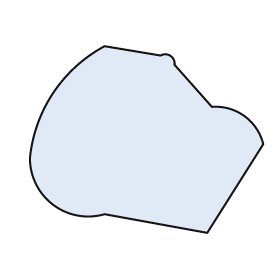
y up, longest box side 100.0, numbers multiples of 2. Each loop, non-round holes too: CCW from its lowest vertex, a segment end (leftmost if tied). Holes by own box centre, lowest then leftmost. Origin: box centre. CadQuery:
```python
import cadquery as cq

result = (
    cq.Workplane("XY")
    .moveTo(26.0, -40.0)
    .lineTo(50.0, -2.0)
    .threePointArc((42.0, 10.0), (28.0, 14.0))
    .lineTo(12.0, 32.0)
    .threePointArc((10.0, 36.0), (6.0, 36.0))
    .lineTo(-18.0, 40.0)
    .threePointArc((-40.0, 20.0), (-50.0, -8.0))
    .threePointArc((-40.0, -28.0), (-18.0, -32.0))
    .close()
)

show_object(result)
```